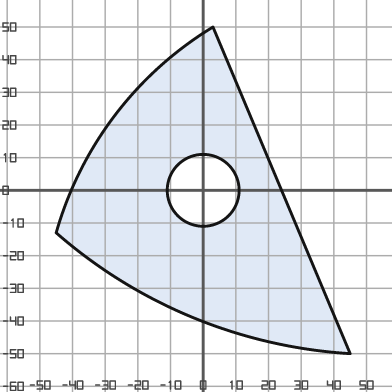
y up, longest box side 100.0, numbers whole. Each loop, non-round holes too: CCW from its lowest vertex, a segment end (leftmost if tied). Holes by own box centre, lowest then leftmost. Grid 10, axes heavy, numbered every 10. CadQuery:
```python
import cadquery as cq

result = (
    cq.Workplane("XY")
    .moveTo(45.0, -50.0)
    .lineTo(3.0, 50.0)
    .threePointArc((-27.0, 23.0), (-45.0, -13.0))
    .threePointArc((-3.0, -39.0), (45.0, -50.0))
    .close()
    .moveTo(0.0, 0.0)
    .circle(11.0)
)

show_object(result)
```